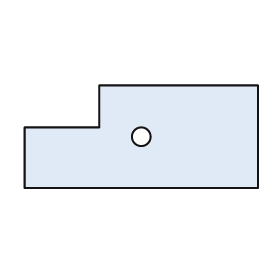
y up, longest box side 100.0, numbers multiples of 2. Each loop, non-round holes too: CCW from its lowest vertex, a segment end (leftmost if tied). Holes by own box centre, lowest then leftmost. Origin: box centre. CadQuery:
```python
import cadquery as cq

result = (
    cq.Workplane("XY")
    .moveTo(-50.0, -22.0)
    .lineTo(50.0, -22.0)
    .lineTo(50.0, 22.0)
    .lineTo(-18.0, 22.0)
    .lineTo(-18.0, 4.0)
    .lineTo(-50.0, 4.0)
    .close()
    .moveTo(0.0, 0.0)
    .circle(4.0)
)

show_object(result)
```